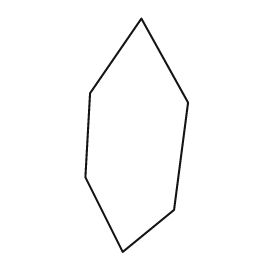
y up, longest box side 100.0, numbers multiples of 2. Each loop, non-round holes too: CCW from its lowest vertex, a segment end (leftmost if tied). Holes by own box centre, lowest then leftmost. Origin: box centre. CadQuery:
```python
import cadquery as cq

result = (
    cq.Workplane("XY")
    .moveTo(-6.0, -50.0)
    .lineTo(16.0, -32.0)
    .lineTo(22.0, 14.0)
    .lineTo(2.0, 50.0)
    .lineTo(-20.0, 18.0)
    .lineTo(-22.0, -18.0)
    .close()
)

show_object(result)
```